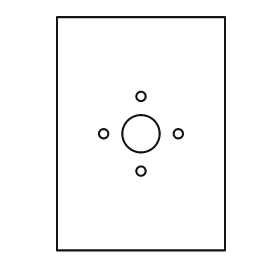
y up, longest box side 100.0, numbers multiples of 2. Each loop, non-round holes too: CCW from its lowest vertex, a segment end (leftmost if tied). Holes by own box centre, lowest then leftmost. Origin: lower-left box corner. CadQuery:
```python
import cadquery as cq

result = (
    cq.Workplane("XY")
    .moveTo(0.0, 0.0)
    .lineTo(72.0, 0.0)
    .lineTo(72.0, 100.0)
    .lineTo(0.0, 100.0)
    .close()
    .moveTo(36.0, 34.0)
    .circle(2.0)
    .moveTo(20.0, 50.0)
    .circle(2.0)
    .moveTo(36.0, 50.0)
    .circle(8.0)
    .moveTo(52.0, 50.0)
    .circle(2.0)
    .moveTo(36.0, 66.0)
    .circle(2.0)
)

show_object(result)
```